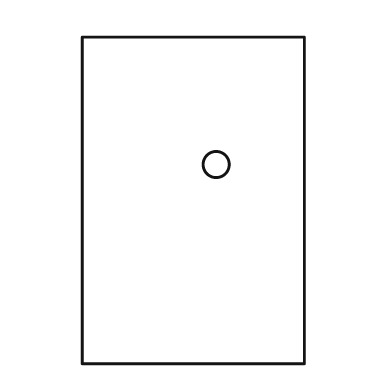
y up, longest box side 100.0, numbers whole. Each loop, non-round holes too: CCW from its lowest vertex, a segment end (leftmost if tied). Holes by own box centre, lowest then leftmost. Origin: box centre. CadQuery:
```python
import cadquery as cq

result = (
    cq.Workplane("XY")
    .moveTo(-34.0, -50.0)
    .lineTo(34.0, -50.0)
    .lineTo(34.0, 50.0)
    .lineTo(-34.0, 50.0)
    .close()
    .moveTo(7.0, 11.0)
    .circle(4.0)
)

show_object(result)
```